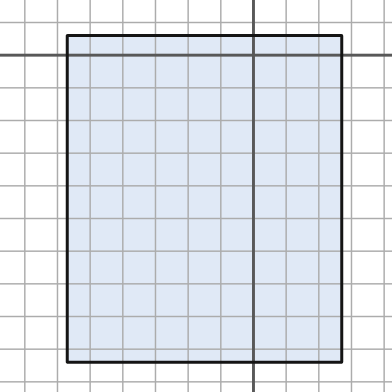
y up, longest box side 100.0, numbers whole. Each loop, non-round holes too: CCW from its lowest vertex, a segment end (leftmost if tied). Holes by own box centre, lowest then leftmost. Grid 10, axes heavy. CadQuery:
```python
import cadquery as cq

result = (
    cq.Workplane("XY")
    .moveTo(-57.0, -94.0)
    .lineTo(27.0, -94.0)
    .lineTo(27.0, 6.0)
    .lineTo(-57.0, 6.0)
    .close()
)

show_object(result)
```